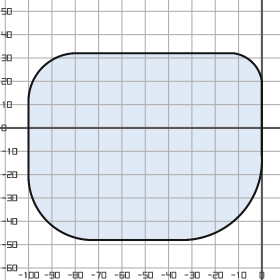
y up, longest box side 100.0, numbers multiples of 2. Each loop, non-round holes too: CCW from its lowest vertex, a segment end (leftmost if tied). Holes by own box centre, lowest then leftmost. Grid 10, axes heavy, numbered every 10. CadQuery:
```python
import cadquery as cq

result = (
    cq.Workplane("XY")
    .moveTo(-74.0, -48.0)
    .lineTo(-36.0, -48.0)
    .threePointArc((-10.0, -38.0), (0.0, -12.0))
    .lineTo(0.0, 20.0)
    .threePointArc((-4.0, 28.0), (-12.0, 32.0))
    .lineTo(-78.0, 32.0)
    .threePointArc((-94.0, 26.0), (-100.0, 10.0))
    .lineTo(-100.0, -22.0)
    .threePointArc((-92.0, -40.0), (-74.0, -48.0))
    .close()
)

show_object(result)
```